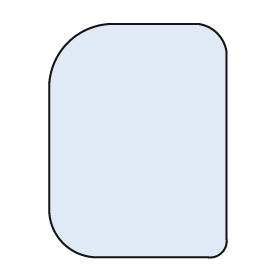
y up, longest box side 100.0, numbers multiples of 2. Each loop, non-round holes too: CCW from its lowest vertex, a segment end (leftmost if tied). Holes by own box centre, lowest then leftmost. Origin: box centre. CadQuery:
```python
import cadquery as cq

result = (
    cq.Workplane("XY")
    .moveTo(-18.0, -50.0)
    .lineTo(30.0, -50.0)
    .threePointArc((36.0, -48.0), (38.0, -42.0))
    .lineTo(38.0, 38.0)
    .threePointArc((34.0, 46.0), (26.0, 50.0))
    .lineTo(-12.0, 50.0)
    .threePointArc((-30.0, 42.0), (-38.0, 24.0))
    .lineTo(-38.0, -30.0)
    .threePointArc((-32.0, -44.0), (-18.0, -50.0))
    .close()
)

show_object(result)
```